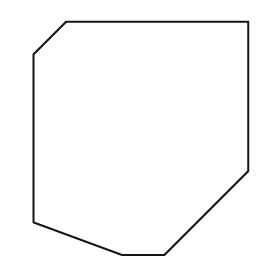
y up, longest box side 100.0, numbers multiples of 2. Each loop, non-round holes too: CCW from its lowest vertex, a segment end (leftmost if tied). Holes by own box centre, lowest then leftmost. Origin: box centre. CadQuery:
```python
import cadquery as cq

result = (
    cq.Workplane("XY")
    .moveTo(-8.0, -50.0)
    .lineTo(10.0, -50.0)
    .lineTo(46.0, -14.0)
    .lineTo(46.0, 50.0)
    .lineTo(-32.0, 50.0)
    .lineTo(-46.0, 36.0)
    .lineTo(-46.0, -36.0)
    .close()
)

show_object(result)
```